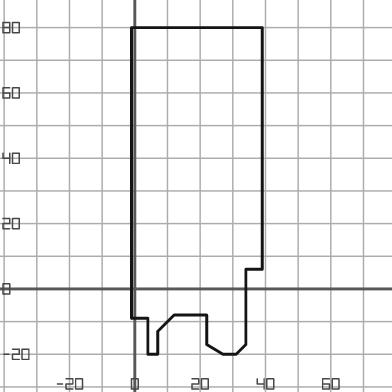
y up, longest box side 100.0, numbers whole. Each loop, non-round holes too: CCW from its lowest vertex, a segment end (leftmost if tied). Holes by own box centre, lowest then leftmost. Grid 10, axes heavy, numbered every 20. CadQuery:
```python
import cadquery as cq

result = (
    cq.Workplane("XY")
    .moveTo(4.0, -20.0)
    .lineTo(7.0, -20.0)
    .lineTo(7.0, -13.0)
    .lineTo(12.0, -8.0)
    .lineTo(22.0, -8.0)
    .lineTo(22.0, -17.0)
    .lineTo(27.0, -20.0)
    .lineTo(31.0, -20.0)
    .lineTo(34.0, -17.0)
    .lineTo(34.0, 6.0)
    .lineTo(39.0, 6.0)
    .lineTo(39.0, 80.0)
    .lineTo(-1.0, 80.0)
    .lineTo(-1.0, -9.0)
    .lineTo(4.0, -9.0)
    .close()
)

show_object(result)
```